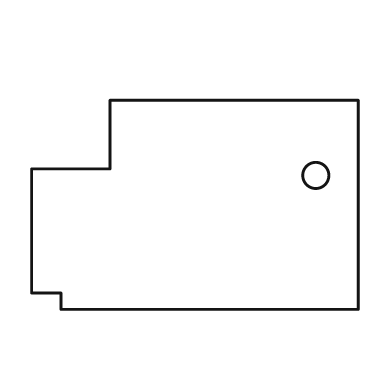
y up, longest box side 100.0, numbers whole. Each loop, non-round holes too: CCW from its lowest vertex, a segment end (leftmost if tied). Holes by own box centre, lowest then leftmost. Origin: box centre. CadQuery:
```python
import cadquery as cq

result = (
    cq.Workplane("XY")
    .moveTo(-41.0, -32.0)
    .lineTo(50.0, -32.0)
    .lineTo(50.0, 32.0)
    .lineTo(-26.0, 32.0)
    .lineTo(-26.0, 11.0)
    .lineTo(-50.0, 11.0)
    .lineTo(-50.0, -27.0)
    .lineTo(-41.0, -27.0)
    .close()
    .moveTo(37.0, 9.0)
    .circle(4.0)
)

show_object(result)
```